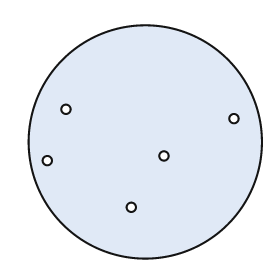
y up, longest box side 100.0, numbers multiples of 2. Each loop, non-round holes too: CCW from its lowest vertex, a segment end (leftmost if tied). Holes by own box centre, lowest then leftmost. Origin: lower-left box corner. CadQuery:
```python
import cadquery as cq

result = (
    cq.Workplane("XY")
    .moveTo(50.0, 50.0)
    .circle(50.0)
    .moveTo(44.0, 22.0)
    .circle(2.0)
    .moveTo(8.0, 42.0)
    .circle(2.0)
    .moveTo(58.0, 44.0)
    .circle(2.0)
    .moveTo(88.0, 60.0)
    .circle(2.0)
    .moveTo(16.0, 64.0)
    .circle(2.0)
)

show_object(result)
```